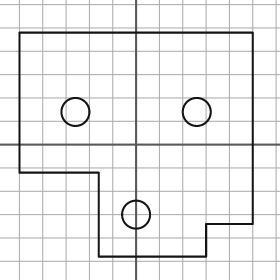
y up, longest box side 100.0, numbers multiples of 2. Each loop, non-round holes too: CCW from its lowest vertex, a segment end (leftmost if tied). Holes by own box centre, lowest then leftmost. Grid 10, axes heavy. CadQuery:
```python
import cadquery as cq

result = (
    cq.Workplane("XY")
    .moveTo(-16.0, -48.0)
    .lineTo(30.0, -48.0)
    .lineTo(30.0, -34.0)
    .lineTo(50.0, -34.0)
    .lineTo(50.0, 48.0)
    .lineTo(-50.0, 48.0)
    .lineTo(-50.0, -12.0)
    .lineTo(-16.0, -12.0)
    .close()
    .moveTo(0.0, -30.0)
    .circle(6.0)
    .moveTo(-26.0, 14.0)
    .circle(6.0)
    .moveTo(26.0, 14.0)
    .circle(6.0)
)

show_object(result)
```